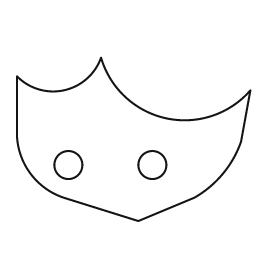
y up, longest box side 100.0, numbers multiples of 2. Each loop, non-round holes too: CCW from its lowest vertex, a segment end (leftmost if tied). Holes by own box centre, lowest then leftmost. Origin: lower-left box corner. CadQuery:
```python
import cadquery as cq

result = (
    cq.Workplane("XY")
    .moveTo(52.0, 0.0)
    .lineTo(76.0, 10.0)
    .threePointArc((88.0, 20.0), (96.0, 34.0))
    .lineTo(100.0, 56.0)
    .threePointArc((64.0, 44.0), (36.0, 70.0))
    .threePointArc((20.0, 56.0), (0.0, 62.0))
    .lineTo(0.0, 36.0)
    .threePointArc((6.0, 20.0), (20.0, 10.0))
    .close()
    .moveTo(22.0, 24.0)
    .circle(6.0)
    .moveTo(58.0, 24.0)
    .circle(6.0)
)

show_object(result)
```